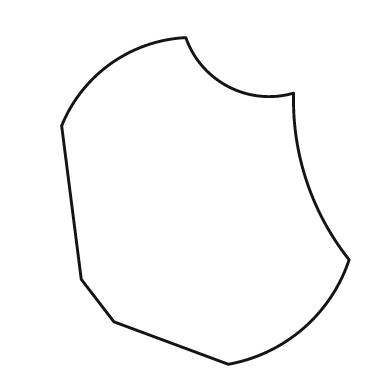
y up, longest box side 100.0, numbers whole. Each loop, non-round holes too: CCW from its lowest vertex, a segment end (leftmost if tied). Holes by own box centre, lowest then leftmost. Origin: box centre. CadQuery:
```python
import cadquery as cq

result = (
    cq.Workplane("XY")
    .moveTo(7.0, -50.0)
    .threePointArc((30.0, -39.0), (44.0, -18.0))
    .threePointArc((31.0, 6.0), (27.0, 33.0))
    .threePointArc((7.0, 35.0), (-6.0, 50.0))
    .threePointArc((-29.0, 42.0), (-44.0, 23.0))
    .lineTo(-38.0, -24.0)
    .lineTo(-28.0, -37.0)
    .close()
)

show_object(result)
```